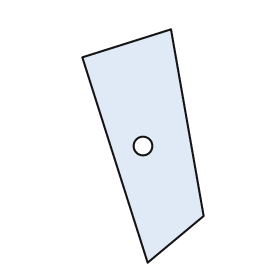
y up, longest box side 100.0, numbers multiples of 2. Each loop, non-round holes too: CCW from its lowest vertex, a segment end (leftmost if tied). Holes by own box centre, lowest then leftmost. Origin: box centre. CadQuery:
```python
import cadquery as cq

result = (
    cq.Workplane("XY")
    .moveTo(2.0, -50.0)
    .lineTo(26.0, -30.0)
    .lineTo(12.0, 50.0)
    .lineTo(-26.0, 38.0)
    .close()
    .moveTo(0.0, 0.0)
    .circle(4.0)
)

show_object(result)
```